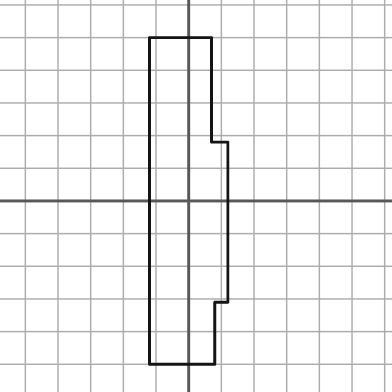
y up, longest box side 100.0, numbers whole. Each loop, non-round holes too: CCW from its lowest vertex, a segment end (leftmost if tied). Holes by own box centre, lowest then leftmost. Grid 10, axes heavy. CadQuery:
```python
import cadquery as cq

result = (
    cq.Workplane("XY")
    .moveTo(-12.0, -50.0)
    .lineTo(8.0, -50.0)
    .lineTo(8.0, -31.0)
    .lineTo(12.0, -31.0)
    .lineTo(12.0, 18.0)
    .lineTo(7.0, 18.0)
    .lineTo(7.0, 50.0)
    .lineTo(-12.0, 50.0)
    .close()
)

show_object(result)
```